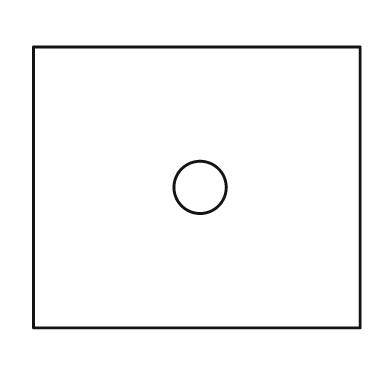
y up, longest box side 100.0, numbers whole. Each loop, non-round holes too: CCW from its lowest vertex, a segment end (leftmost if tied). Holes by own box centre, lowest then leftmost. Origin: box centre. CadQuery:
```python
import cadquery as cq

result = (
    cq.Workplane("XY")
    .moveTo(-50.0, -43.0)
    .lineTo(50.0, -43.0)
    .lineTo(50.0, 43.0)
    .lineTo(-50.0, 43.0)
    .close()
    .moveTo(1.0, 0.0)
    .circle(8.0)
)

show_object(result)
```